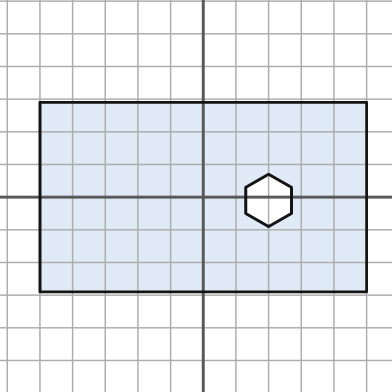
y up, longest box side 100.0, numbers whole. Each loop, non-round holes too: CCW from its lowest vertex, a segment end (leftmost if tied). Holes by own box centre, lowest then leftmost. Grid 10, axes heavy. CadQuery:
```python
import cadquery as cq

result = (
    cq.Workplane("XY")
    .moveTo(-50.0, -29.0)
    .lineTo(50.0, -29.0)
    .lineTo(50.0, 29.0)
    .lineTo(-50.0, 29.0)
    .close()
    .moveTo(20.0, -9.0)
    .lineTo(27.0, -5.0)
    .lineTo(27.0, 3.0)
    .lineTo(20.0, 7.0)
    .lineTo(13.0, 3.0)
    .lineTo(13.0, -5.0)
    .close()
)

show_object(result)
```